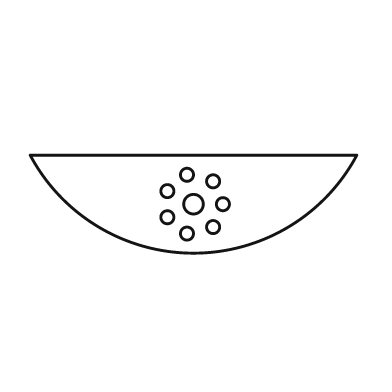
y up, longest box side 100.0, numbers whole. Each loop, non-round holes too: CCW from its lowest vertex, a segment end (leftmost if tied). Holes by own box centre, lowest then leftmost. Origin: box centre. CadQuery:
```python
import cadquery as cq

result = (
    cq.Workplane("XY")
    .moveTo(-50.0, 15.0)
    .threePointArc((0.0, -15.0), (50.0, 15.0))
    .close()
    .moveTo(-2.0, -9.0)
    .circle(2.0)
    .moveTo(6.0, -7.0)
    .circle(2.0)
    .moveTo(-8.0, -4.0)
    .circle(2.0)
    .moveTo(0.0, 0.0)
    .circle(3.0)
    .moveTo(9.0, 0.0)
    .circle(2.0)
    .moveTo(-8.0, 4.0)
    .circle(2.0)
    .moveTo(6.0, 7.0)
    .circle(2.0)
    .moveTo(-2.0, 9.0)
    .circle(2.0)
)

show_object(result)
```